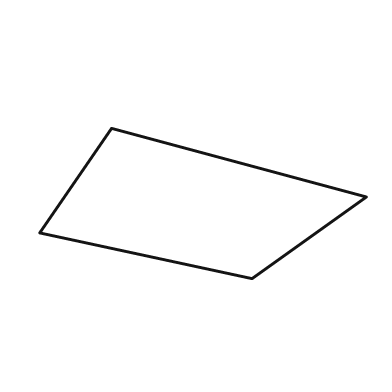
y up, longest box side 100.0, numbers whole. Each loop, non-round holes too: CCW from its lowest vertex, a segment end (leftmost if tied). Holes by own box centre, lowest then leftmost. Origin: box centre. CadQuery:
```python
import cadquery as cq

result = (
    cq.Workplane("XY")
    .moveTo(15.0, -23.0)
    .lineTo(50.0, 2.0)
    .lineTo(-28.0, 23.0)
    .lineTo(-50.0, -9.0)
    .close()
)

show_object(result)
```